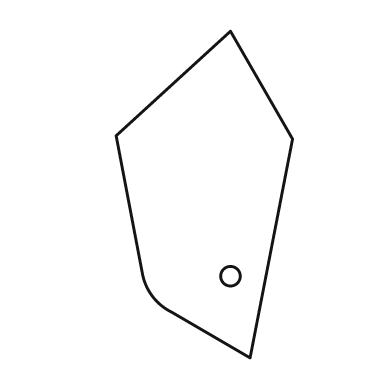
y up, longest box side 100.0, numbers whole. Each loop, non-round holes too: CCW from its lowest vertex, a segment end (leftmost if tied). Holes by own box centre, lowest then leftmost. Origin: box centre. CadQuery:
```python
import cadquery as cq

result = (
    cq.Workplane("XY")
    .moveTo(14.0, -50.0)
    .lineTo(27.0, 17.0)
    .lineTo(8.0, 50.0)
    .lineTo(-27.0, 18.0)
    .lineTo(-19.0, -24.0)
    .threePointArc((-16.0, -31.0), (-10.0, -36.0))
    .close()
    .moveTo(8.0, -25.0)
    .circle(3.0)
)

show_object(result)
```